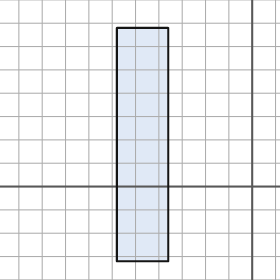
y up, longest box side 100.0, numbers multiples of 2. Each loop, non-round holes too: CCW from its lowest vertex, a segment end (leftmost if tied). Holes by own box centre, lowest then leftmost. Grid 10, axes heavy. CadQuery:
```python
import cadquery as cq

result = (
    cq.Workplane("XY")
    .moveTo(-58.0, -32.0)
    .lineTo(-36.0, -32.0)
    .lineTo(-36.0, 68.0)
    .lineTo(-58.0, 68.0)
    .close()
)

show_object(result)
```